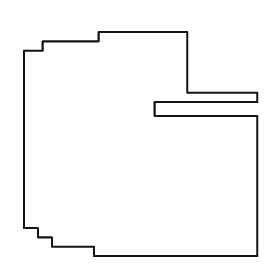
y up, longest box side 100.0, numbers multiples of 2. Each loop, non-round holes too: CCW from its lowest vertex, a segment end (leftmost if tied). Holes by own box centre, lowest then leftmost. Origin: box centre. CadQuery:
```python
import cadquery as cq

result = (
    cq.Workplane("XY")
    .moveTo(-20.0, -48.0)
    .lineTo(50.0, -48.0)
    .lineTo(50.0, 12.0)
    .lineTo(6.0, 12.0)
    .lineTo(6.0, 18.0)
    .lineTo(50.0, 18.0)
    .lineTo(50.0, 22.0)
    .lineTo(20.0, 22.0)
    .lineTo(20.0, 48.0)
    .lineTo(-18.0, 48.0)
    .lineTo(-18.0, 44.0)
    .lineTo(-42.0, 44.0)
    .lineTo(-42.0, 40.0)
    .lineTo(-50.0, 40.0)
    .lineTo(-50.0, -36.0)
    .lineTo(-44.0, -36.0)
    .lineTo(-44.0, -40.0)
    .lineTo(-38.0, -40.0)
    .lineTo(-38.0, -44.0)
    .lineTo(-20.0, -44.0)
    .close()
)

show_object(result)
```